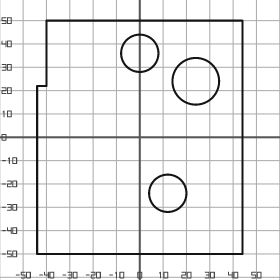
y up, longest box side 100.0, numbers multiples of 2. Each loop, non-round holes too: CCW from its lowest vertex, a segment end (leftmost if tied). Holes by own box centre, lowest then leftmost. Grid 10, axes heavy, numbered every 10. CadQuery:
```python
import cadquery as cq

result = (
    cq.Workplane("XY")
    .moveTo(-44.0, -50.0)
    .lineTo(44.0, -50.0)
    .lineTo(44.0, 50.0)
    .lineTo(-40.0, 50.0)
    .lineTo(-40.0, 22.0)
    .lineTo(-44.0, 22.0)
    .close()
    .moveTo(12.0, -24.0)
    .circle(8.0)
    .moveTo(24.0, 24.0)
    .circle(10.0)
    .moveTo(0.0, 36.0)
    .circle(8.0)
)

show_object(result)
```